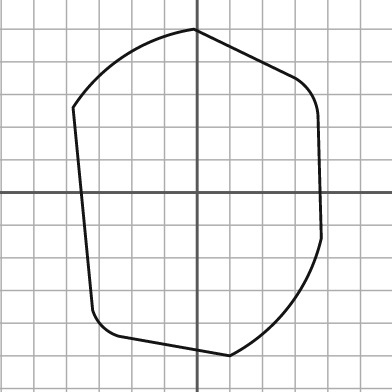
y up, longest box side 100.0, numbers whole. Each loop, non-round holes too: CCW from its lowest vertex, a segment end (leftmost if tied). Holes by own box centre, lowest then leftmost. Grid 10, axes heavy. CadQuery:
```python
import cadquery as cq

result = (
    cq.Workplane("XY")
    .moveTo(10.0, -50.0)
    .threePointArc((28.0, -35.0), (38.0, -14.0))
    .lineTo(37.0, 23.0)
    .threePointArc((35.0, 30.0), (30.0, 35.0))
    .lineTo(-1.0, 50.0)
    .threePointArc((-22.0, 42.0), (-38.0, 26.0))
    .lineTo(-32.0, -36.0)
    .threePointArc((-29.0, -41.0), (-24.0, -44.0))
    .close()
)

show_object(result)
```